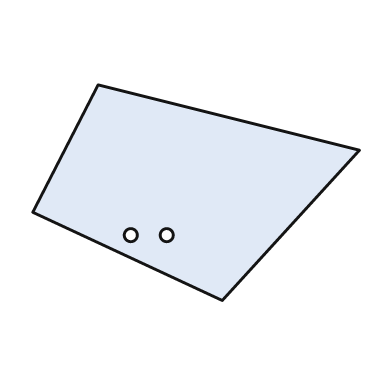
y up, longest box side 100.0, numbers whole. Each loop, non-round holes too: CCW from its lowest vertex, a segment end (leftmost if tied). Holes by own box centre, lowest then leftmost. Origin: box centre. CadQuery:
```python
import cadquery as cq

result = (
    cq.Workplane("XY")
    .moveTo(8.0, -33.0)
    .lineTo(50.0, 13.0)
    .lineTo(-30.0, 33.0)
    .lineTo(-50.0, -6.0)
    .close()
    .moveTo(-20.0, -13.0)
    .circle(2.0)
    .moveTo(-9.0, -13.0)
    .circle(2.0)
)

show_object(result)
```